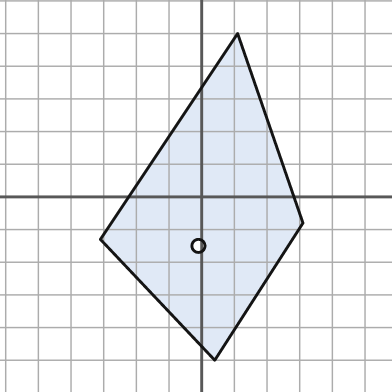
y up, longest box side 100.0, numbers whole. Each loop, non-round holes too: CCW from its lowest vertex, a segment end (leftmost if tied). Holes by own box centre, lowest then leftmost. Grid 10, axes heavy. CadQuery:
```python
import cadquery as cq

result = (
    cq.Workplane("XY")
    .moveTo(4.0, -50.0)
    .lineTo(31.0, -8.0)
    .lineTo(11.0, 50.0)
    .lineTo(-31.0, -13.0)
    .close()
    .moveTo(-1.0, -15.0)
    .circle(2.0)
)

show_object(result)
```